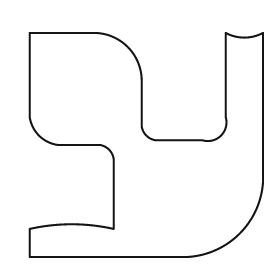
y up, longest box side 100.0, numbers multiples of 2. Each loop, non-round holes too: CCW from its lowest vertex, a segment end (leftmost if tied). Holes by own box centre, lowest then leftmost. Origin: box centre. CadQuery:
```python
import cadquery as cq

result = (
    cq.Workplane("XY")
    .moveTo(-50.0, -48.0)
    .lineTo(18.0, -48.0)
    .threePointArc((40.0, -38.0), (50.0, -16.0))
    .lineTo(50.0, 48.0)
    .threePointArc((42.0, 46.0), (34.0, 48.0))
    .lineTo(34.0, 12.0)
    .threePointArc((32.0, 4.0), (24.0, 2.0))
    .lineTo(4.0, 2.0)
    .threePointArc((0.0, 4.0), (-2.0, 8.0))
    .lineTo(-2.0, 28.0)
    .threePointArc((-8.0, 42.0), (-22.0, 48.0))
    .lineTo(-50.0, 48.0)
    .lineTo(-50.0, 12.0)
    .threePointArc((-46.0, 4.0), (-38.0, 0.0))
    .lineTo(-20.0, 0.0)
    .threePointArc((-16.0, -2.0), (-14.0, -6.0))
    .lineTo(-14.0, -36.0)
    .threePointArc((-32.0, -34.0), (-50.0, -36.0))
    .close()
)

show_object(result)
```